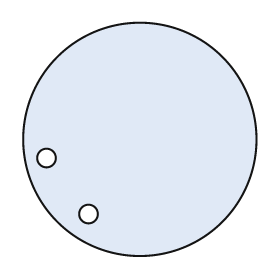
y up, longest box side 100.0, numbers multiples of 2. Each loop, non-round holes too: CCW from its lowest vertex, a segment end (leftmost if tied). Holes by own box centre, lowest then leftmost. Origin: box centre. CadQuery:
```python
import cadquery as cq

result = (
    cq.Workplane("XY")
    .moveTo(0.0, 0.0)
    .circle(50.0)
    .moveTo(-22.0, -32.0)
    .circle(4.0)
    .moveTo(-40.0, -8.0)
    .circle(4.0)
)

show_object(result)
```